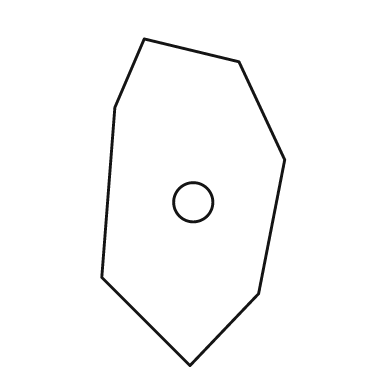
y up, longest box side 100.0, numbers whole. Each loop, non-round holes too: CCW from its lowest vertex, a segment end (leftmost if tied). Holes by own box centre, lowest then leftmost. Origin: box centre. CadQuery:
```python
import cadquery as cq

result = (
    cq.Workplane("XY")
    .moveTo(-1.0, -50.0)
    .lineTo(20.0, -28.0)
    .lineTo(28.0, 13.0)
    .lineTo(14.0, 43.0)
    .lineTo(-15.0, 50.0)
    .lineTo(-24.0, 29.0)
    .lineTo(-28.0, -23.0)
    .close()
    .moveTo(0.0, 0.0)
    .circle(6.0)
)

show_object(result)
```